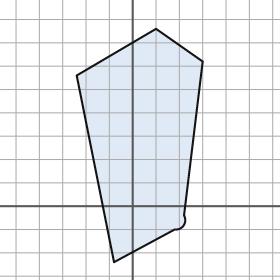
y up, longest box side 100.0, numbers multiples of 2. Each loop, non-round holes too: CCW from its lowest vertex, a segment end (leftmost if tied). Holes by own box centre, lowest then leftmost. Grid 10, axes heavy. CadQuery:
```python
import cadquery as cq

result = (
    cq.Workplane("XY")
    .moveTo(-8.0, -24.0)
    .lineTo(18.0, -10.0)
    .threePointArc((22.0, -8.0), (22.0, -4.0))
    .lineTo(30.0, 62.0)
    .lineTo(10.0, 76.0)
    .lineTo(-24.0, 56.0)
    .close()
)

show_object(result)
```